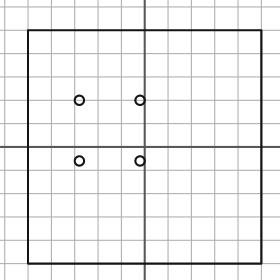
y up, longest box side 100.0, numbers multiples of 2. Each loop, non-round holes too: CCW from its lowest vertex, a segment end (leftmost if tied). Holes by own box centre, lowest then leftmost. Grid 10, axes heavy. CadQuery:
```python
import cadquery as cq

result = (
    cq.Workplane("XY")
    .moveTo(-50.0, -50.0)
    .lineTo(50.0, -50.0)
    .lineTo(50.0, 50.0)
    .lineTo(-50.0, 50.0)
    .close()
    .moveTo(-28.0, -6.0)
    .circle(2.0)
    .moveTo(-2.0, -6.0)
    .circle(2.0)
    .moveTo(-28.0, 20.0)
    .circle(2.0)
    .moveTo(-2.0, 20.0)
    .circle(2.0)
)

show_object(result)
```